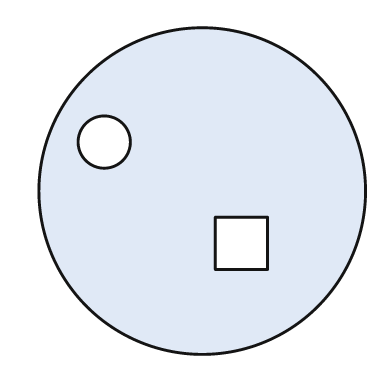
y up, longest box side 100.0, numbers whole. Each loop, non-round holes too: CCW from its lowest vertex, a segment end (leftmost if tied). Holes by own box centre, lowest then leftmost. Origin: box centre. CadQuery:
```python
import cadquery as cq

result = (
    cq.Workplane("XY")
    .moveTo(0.0, 0.0)
    .circle(50.0)
    .moveTo(4.0, -24.0)
    .lineTo(20.0, -24.0)
    .lineTo(20.0, -8.0)
    .lineTo(4.0, -8.0)
    .close()
    .moveTo(-30.0, 15.0)
    .circle(8.0)
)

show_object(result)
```